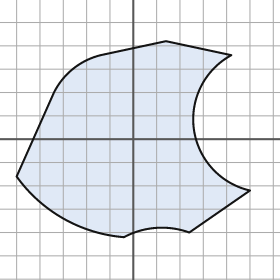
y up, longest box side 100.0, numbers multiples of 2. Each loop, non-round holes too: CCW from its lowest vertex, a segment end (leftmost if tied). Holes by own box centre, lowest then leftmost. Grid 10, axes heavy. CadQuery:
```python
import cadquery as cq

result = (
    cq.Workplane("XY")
    .moveTo(-4.0, -42.0)
    .threePointArc((10.0, -38.0), (24.0, -40.0))
    .lineTo(50.0, -22.0)
    .threePointArc((26.0, 4.0), (42.0, 36.0))
    .lineTo(14.0, 42.0)
    .lineTo(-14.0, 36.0)
    .threePointArc((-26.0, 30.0), (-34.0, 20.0))
    .lineTo(-50.0, -16.0)
    .threePointArc((-30.0, -34.0), (-4.0, -42.0))
    .close()
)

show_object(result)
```